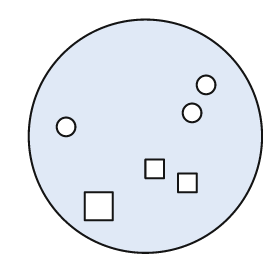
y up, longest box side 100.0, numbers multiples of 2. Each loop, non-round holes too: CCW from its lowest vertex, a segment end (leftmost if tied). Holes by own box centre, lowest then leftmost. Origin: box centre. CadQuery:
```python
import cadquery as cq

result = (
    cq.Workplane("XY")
    .moveTo(0.0, 0.0)
    .circle(50.0)
    .moveTo(-26.0, -36.0)
    .lineTo(-14.0, -36.0)
    .lineTo(-14.0, -24.0)
    .lineTo(-26.0, -24.0)
    .close()
    .moveTo(14.0, -24.0)
    .lineTo(22.0, -24.0)
    .lineTo(22.0, -16.0)
    .lineTo(14.0, -16.0)
    .close()
    .moveTo(0.0, -18.0)
    .lineTo(8.0, -18.0)
    .lineTo(8.0, -10.0)
    .lineTo(0.0, -10.0)
    .close()
    .moveTo(-34.0, 4.0)
    .circle(4.0)
    .moveTo(20.0, 10.0)
    .circle(4.0)
    .moveTo(26.0, 22.0)
    .circle(4.0)
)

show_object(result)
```